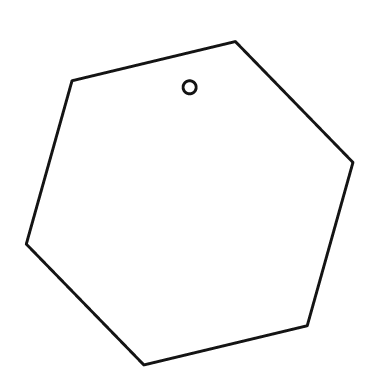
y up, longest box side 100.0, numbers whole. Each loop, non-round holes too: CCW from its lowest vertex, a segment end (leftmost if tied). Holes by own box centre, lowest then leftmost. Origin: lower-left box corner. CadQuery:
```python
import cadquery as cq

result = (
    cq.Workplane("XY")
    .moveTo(36.0, 0.0)
    .lineTo(86.0, 12.0)
    .lineTo(100.0, 62.0)
    .lineTo(64.0, 99.0)
    .lineTo(14.0, 87.0)
    .lineTo(0.0, 37.0)
    .close()
    .moveTo(50.0, 85.0)
    .circle(2.0)
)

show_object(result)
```